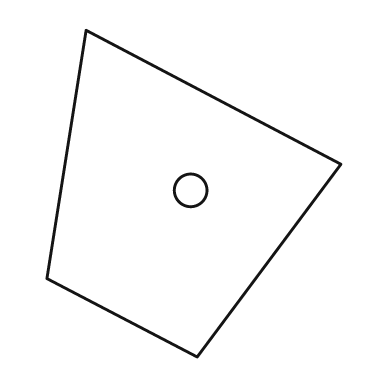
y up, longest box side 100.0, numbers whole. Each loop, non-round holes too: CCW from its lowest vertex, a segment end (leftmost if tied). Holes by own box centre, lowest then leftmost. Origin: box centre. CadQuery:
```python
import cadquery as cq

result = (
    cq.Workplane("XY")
    .moveTo(1.0, -50.0)
    .lineTo(45.0, 9.0)
    .lineTo(-33.0, 50.0)
    .lineTo(-45.0, -26.0)
    .close()
    .moveTo(-1.0, 1.0)
    .circle(5.0)
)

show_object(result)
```